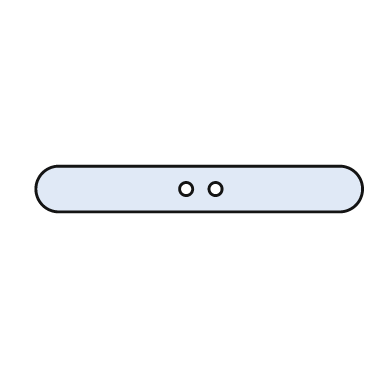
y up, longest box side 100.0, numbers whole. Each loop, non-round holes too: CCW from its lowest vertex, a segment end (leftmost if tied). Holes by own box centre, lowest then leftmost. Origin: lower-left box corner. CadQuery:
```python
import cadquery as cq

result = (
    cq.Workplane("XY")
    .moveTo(7.0, 0.0)
    .lineTo(93.0, 0.0)
    .threePointArc((100.0, 7.0), (93.0, 14.0))
    .lineTo(7.0, 14.0)
    .threePointArc((0.0, 7.0), (7.0, 0.0))
    .close()
    .moveTo(46.0, 7.0)
    .circle(2.0)
    .moveTo(55.0, 7.0)
    .circle(2.0)
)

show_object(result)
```